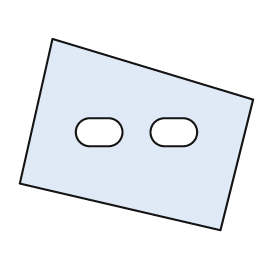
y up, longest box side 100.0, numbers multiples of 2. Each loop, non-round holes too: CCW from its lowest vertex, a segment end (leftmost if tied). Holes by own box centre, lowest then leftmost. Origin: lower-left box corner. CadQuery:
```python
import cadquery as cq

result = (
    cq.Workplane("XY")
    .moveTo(86.0, 0.0)
    .lineTo(100.0, 56.0)
    .lineTo(14.0, 82.0)
    .lineTo(0.0, 20.0)
    .close()
    .moveTo(30.0, 36.0)
    .lineTo(38.0, 36.0)
    .threePointArc((44.0, 42.0), (38.0, 48.0))
    .lineTo(30.0, 48.0)
    .threePointArc((24.0, 42.0), (30.0, 36.0))
    .close()
    .moveTo(62.0, 36.0)
    .lineTo(70.0, 36.0)
    .threePointArc((76.0, 42.0), (70.0, 48.0))
    .lineTo(62.0, 48.0)
    .threePointArc((56.0, 42.0), (62.0, 36.0))
    .close()
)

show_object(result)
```